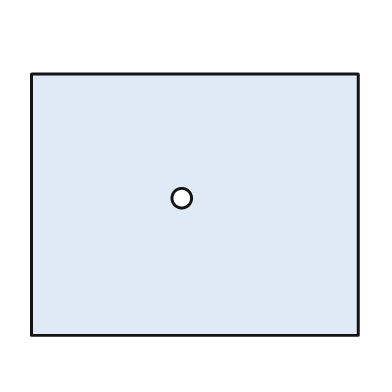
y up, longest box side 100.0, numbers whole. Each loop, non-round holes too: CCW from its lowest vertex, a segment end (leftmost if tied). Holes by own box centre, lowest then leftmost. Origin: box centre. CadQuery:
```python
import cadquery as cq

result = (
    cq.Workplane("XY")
    .moveTo(-50.0, -40.0)
    .lineTo(50.0, -40.0)
    .lineTo(50.0, 40.0)
    .lineTo(-50.0, 40.0)
    .close()
    .moveTo(-4.0, 2.0)
    .circle(3.0)
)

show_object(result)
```